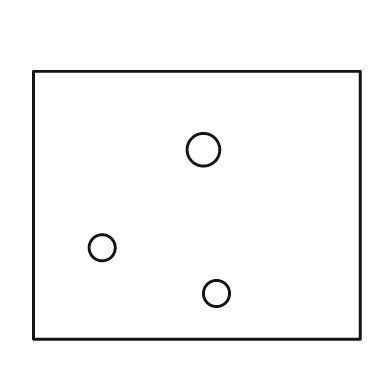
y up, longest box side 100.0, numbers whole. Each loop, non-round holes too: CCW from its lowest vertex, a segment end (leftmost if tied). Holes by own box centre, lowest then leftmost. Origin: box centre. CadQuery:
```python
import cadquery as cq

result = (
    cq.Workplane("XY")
    .moveTo(-50.0, -41.0)
    .lineTo(50.0, -41.0)
    .lineTo(50.0, 41.0)
    .lineTo(-50.0, 41.0)
    .close()
    .moveTo(6.0, -27.0)
    .circle(4.0)
    .moveTo(-29.0, -13.0)
    .circle(4.0)
    .moveTo(2.0, 17.0)
    .circle(5.0)
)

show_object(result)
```